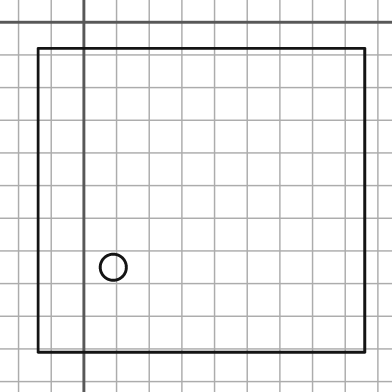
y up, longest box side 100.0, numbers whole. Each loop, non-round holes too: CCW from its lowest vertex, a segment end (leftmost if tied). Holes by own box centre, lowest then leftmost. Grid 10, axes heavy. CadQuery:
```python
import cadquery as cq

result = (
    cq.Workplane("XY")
    .moveTo(-14.0, -101.0)
    .lineTo(86.0, -101.0)
    .lineTo(86.0, -8.0)
    .lineTo(-14.0, -8.0)
    .close()
    .moveTo(9.0, -75.0)
    .circle(4.0)
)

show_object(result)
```